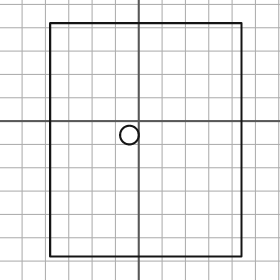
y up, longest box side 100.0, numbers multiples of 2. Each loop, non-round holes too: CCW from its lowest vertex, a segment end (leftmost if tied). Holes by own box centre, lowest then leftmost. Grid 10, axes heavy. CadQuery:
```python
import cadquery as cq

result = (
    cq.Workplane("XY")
    .moveTo(-38.0, -58.0)
    .lineTo(44.0, -58.0)
    .lineTo(44.0, 42.0)
    .lineTo(-38.0, 42.0)
    .close()
    .moveTo(-4.0, -6.0)
    .circle(4.0)
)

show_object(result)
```